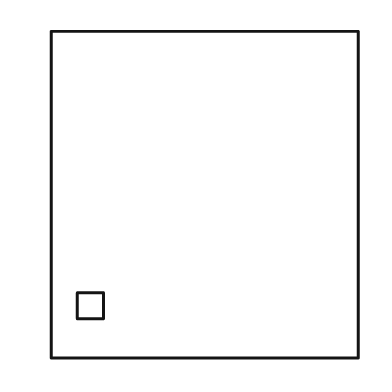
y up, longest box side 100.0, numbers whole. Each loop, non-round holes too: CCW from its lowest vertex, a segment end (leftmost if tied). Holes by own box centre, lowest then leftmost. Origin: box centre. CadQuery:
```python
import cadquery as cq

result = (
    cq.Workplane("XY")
    .moveTo(-47.0, -50.0)
    .lineTo(47.0, -50.0)
    .lineTo(47.0, 50.0)
    .lineTo(-47.0, 50.0)
    .close()
    .moveTo(-39.0, -38.0)
    .lineTo(-31.0, -38.0)
    .lineTo(-31.0, -30.0)
    .lineTo(-39.0, -30.0)
    .close()
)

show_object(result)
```